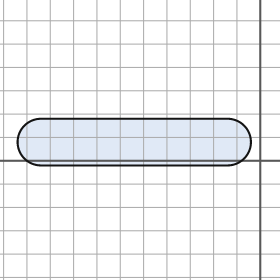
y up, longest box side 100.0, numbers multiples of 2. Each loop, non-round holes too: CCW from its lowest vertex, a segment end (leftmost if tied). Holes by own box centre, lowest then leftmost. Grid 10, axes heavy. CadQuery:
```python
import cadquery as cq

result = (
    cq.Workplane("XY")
    .moveTo(-94.0, -2.0)
    .lineTo(-14.0, -2.0)
    .threePointArc((-4.0, 8.0), (-14.0, 18.0))
    .lineTo(-94.0, 18.0)
    .threePointArc((-104.0, 8.0), (-94.0, -2.0))
    .close()
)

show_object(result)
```